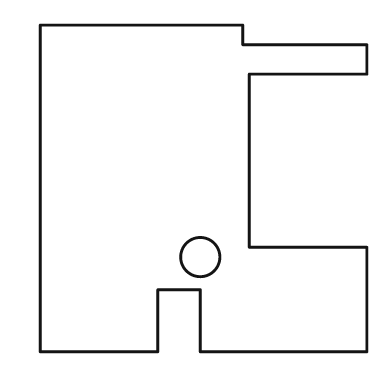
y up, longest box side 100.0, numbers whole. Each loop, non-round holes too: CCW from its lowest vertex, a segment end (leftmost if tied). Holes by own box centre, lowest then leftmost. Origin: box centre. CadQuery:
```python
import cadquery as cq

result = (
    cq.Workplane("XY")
    .moveTo(-50.0, -50.0)
    .lineTo(-14.0, -50.0)
    .lineTo(-14.0, -31.0)
    .lineTo(-1.0, -31.0)
    .lineTo(-1.0, -50.0)
    .lineTo(50.0, -50.0)
    .lineTo(50.0, -18.0)
    .lineTo(14.0, -18.0)
    .lineTo(14.0, 35.0)
    .lineTo(50.0, 35.0)
    .lineTo(50.0, 44.0)
    .lineTo(12.0, 44.0)
    .lineTo(12.0, 50.0)
    .lineTo(-50.0, 50.0)
    .close()
    .moveTo(-1.0, -21.0)
    .circle(6.0)
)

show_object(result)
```